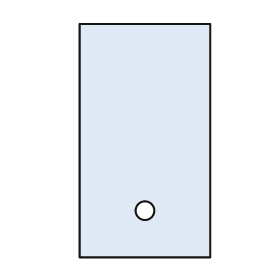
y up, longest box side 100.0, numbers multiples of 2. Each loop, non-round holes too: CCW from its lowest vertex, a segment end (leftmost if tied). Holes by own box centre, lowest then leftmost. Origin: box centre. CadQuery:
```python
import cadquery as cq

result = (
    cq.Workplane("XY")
    .moveTo(-28.0, -50.0)
    .lineTo(28.0, -50.0)
    .lineTo(28.0, 50.0)
    .lineTo(-28.0, 50.0)
    .close()
    .moveTo(0.0, -30.0)
    .circle(4.0)
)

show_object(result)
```